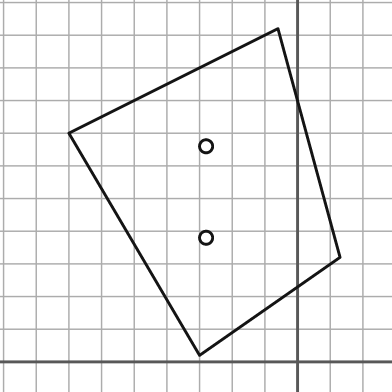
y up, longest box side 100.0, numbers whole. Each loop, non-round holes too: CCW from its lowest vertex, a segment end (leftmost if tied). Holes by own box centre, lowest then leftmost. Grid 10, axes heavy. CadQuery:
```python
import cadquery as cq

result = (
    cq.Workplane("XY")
    .moveTo(-30.0, 2.0)
    .lineTo(13.0, 32.0)
    .lineTo(-6.0, 102.0)
    .lineTo(-70.0, 70.0)
    .close()
    .moveTo(-28.0, 38.0)
    .circle(2.0)
    .moveTo(-28.0, 66.0)
    .circle(2.0)
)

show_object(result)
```